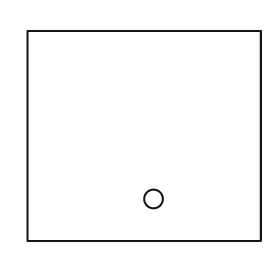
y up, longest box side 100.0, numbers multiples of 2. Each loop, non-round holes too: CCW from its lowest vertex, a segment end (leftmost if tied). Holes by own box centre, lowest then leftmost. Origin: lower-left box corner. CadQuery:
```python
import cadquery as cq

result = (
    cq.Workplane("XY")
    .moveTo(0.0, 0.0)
    .lineTo(100.0, 0.0)
    .lineTo(100.0, 90.0)
    .lineTo(0.0, 90.0)
    .close()
    .moveTo(54.0, 18.0)
    .circle(4.0)
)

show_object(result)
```